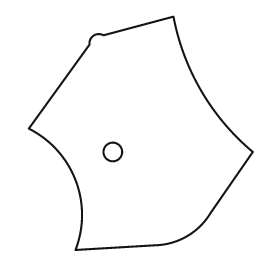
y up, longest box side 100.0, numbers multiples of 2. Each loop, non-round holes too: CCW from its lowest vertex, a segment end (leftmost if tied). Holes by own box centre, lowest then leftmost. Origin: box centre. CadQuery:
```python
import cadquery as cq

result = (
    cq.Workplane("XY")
    .moveTo(-28.0, -50.0)
    .lineTo(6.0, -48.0)
    .threePointArc((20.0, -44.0), (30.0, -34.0))
    .lineTo(48.0, -8.0)
    .threePointArc((26.0, 18.0), (14.0, 50.0))
    .lineTo(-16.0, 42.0)
    .threePointArc((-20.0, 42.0), (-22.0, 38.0))
    .lineTo(-48.0, 2.0)
    .threePointArc((-28.0, -20.0), (-28.0, -50.0))
    .close()
    .moveTo(-12.0, -8.0)
    .circle(4.0)
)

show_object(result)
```